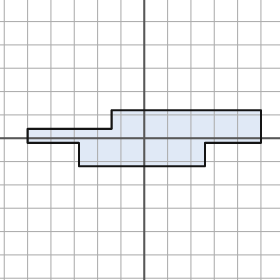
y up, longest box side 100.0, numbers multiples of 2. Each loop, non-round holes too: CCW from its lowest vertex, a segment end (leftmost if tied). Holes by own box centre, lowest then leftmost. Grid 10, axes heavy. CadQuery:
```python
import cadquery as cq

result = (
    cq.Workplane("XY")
    .moveTo(-28.0, -12.0)
    .lineTo(26.0, -12.0)
    .lineTo(26.0, -2.0)
    .lineTo(50.0, -2.0)
    .lineTo(50.0, 12.0)
    .lineTo(-14.0, 12.0)
    .lineTo(-14.0, 4.0)
    .lineTo(-50.0, 4.0)
    .lineTo(-50.0, -2.0)
    .lineTo(-28.0, -2.0)
    .close()
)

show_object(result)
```